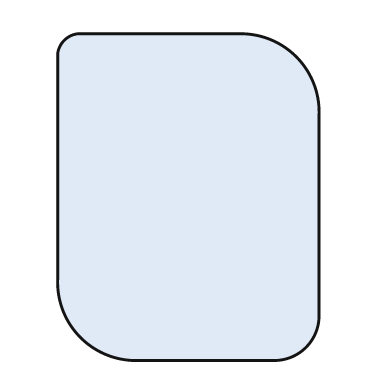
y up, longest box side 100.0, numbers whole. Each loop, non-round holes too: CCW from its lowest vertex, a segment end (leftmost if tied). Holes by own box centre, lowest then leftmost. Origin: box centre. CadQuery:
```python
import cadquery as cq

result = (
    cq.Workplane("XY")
    .moveTo(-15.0, -50.0)
    .lineTo(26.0, -50.0)
    .threePointArc((36.0, -46.0), (40.0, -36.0))
    .lineTo(40.0, 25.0)
    .threePointArc((33.0, 43.0), (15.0, 50.0))
    .lineTo(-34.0, 50.0)
    .threePointArc((-38.0, 48.0), (-40.0, 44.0))
    .lineTo(-40.0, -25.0)
    .threePointArc((-33.0, -43.0), (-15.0, -50.0))
    .close()
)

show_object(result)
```